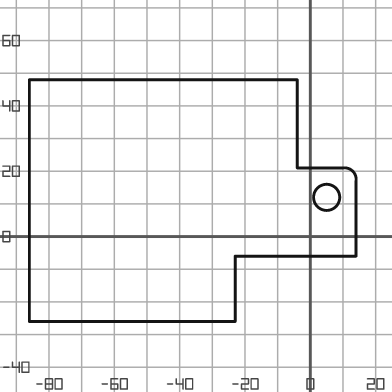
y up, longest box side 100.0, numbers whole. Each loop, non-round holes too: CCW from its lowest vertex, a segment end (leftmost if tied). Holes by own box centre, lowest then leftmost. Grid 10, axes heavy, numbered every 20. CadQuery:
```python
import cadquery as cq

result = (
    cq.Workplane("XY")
    .moveTo(-86.0, -26.0)
    .lineTo(-23.0, -26.0)
    .lineTo(-23.0, -6.0)
    .lineTo(14.0, -6.0)
    .lineTo(14.0, 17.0)
    .threePointArc((13.0, 20.0), (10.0, 21.0))
    .lineTo(-4.0, 21.0)
    .lineTo(-4.0, 48.0)
    .lineTo(-86.0, 48.0)
    .close()
    .moveTo(5.0, 12.0)
    .circle(4.0)
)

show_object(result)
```